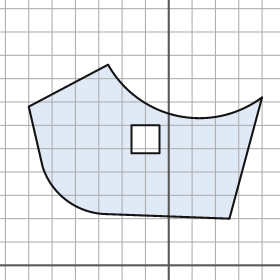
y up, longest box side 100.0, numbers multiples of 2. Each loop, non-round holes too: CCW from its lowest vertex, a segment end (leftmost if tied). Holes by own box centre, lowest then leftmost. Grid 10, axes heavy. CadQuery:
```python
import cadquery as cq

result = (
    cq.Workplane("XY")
    .moveTo(26.0, 20.0)
    .lineTo(40.0, 72.0)
    .threePointArc((4.0, 64.0), (-26.0, 86.0))
    .lineTo(-60.0, 68.0)
    .lineTo(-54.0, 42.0)
    .threePointArc((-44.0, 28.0), (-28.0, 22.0))
    .close()
    .moveTo(-16.0, 48.0)
    .lineTo(-4.0, 48.0)
    .lineTo(-4.0, 60.0)
    .lineTo(-16.0, 60.0)
    .close()
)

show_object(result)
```